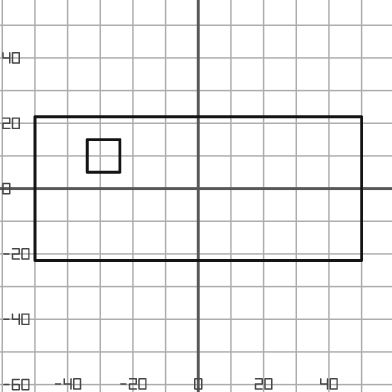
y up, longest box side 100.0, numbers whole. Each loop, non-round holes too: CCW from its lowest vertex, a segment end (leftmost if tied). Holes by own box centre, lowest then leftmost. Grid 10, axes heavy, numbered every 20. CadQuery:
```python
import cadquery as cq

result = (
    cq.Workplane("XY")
    .moveTo(-50.0, -22.0)
    .lineTo(50.0, -22.0)
    .lineTo(50.0, 22.0)
    .lineTo(-50.0, 22.0)
    .close()
    .moveTo(-34.0, 5.0)
    .lineTo(-24.0, 5.0)
    .lineTo(-24.0, 15.0)
    .lineTo(-34.0, 15.0)
    .close()
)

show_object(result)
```